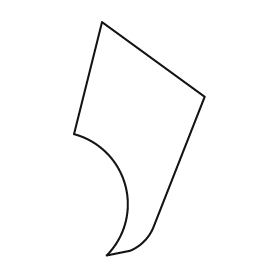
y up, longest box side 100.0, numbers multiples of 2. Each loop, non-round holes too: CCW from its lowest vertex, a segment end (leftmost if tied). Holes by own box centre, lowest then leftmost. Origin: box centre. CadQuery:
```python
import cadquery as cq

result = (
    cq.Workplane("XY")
    .moveTo(-14.0, -50.0)
    .lineTo(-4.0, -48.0)
    .threePointArc((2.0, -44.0), (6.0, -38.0))
    .lineTo(28.0, 18.0)
    .lineTo(-16.0, 50.0)
    .lineTo(-28.0, 2.0)
    .threePointArc((-6.0, -20.0), (-14.0, -50.0))
    .close()
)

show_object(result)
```